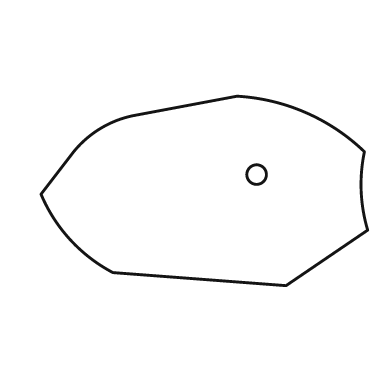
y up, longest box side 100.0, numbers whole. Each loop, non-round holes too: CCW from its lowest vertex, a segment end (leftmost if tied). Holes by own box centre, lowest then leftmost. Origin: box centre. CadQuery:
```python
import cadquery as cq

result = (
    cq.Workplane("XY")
    .moveTo(25.0, -29.0)
    .lineTo(50.0, -12.0)
    .threePointArc((48.0, 0.0), (49.0, 12.0))
    .threePointArc((31.0, 24.0), (10.0, 29.0))
    .lineTo(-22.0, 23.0)
    .threePointArc((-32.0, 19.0), (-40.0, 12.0))
    .lineTo(-50.0, -1.0)
    .threePointArc((-41.0, -15.0), (-28.0, -25.0))
    .close()
    .moveTo(16.0, 5.0)
    .circle(3.0)
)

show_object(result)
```